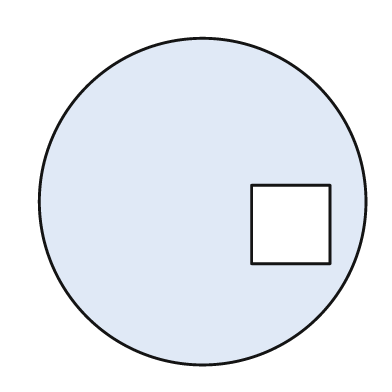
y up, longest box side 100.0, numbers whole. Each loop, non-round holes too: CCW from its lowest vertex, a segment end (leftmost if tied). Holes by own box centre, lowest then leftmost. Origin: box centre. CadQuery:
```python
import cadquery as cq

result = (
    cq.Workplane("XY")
    .moveTo(0.0, 0.0)
    .circle(50.0)
    .moveTo(15.0, -19.0)
    .lineTo(39.0, -19.0)
    .lineTo(39.0, 5.0)
    .lineTo(15.0, 5.0)
    .close()
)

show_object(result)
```